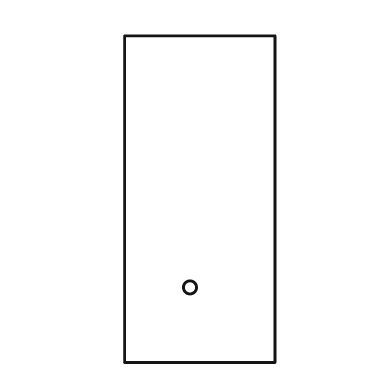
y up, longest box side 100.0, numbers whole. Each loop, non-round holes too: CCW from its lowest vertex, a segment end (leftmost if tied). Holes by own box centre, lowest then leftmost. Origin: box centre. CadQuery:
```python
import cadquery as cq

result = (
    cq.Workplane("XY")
    .moveTo(-23.0, -50.0)
    .lineTo(23.0, -50.0)
    .lineTo(23.0, 50.0)
    .lineTo(-23.0, 50.0)
    .close()
    .moveTo(-3.0, -27.0)
    .circle(2.0)
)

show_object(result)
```